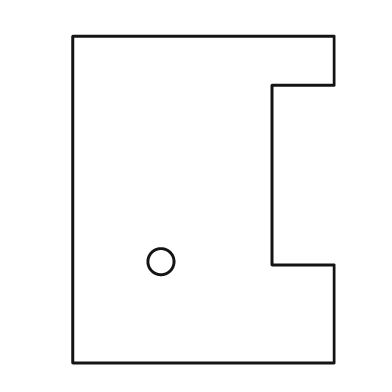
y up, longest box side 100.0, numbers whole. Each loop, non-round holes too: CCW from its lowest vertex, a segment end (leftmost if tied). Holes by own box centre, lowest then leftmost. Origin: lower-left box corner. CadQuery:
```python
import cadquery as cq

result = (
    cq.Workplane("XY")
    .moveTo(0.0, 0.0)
    .lineTo(80.0, 0.0)
    .lineTo(80.0, 30.0)
    .lineTo(61.0, 30.0)
    .lineTo(61.0, 85.0)
    .lineTo(80.0, 85.0)
    .lineTo(80.0, 100.0)
    .lineTo(0.0, 100.0)
    .close()
    .moveTo(27.0, 31.0)
    .circle(4.0)
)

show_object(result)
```